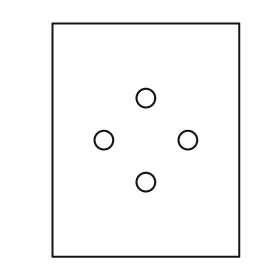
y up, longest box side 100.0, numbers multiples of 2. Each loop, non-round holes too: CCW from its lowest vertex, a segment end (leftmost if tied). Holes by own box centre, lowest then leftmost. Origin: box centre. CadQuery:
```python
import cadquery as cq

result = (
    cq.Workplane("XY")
    .moveTo(-40.0, -50.0)
    .lineTo(40.0, -50.0)
    .lineTo(40.0, 50.0)
    .lineTo(-40.0, 50.0)
    .close()
    .moveTo(0.0, -18.0)
    .circle(4.0)
    .moveTo(-18.0, 0.0)
    .circle(4.0)
    .moveTo(18.0, 0.0)
    .circle(4.0)
    .moveTo(0.0, 18.0)
    .circle(4.0)
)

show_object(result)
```